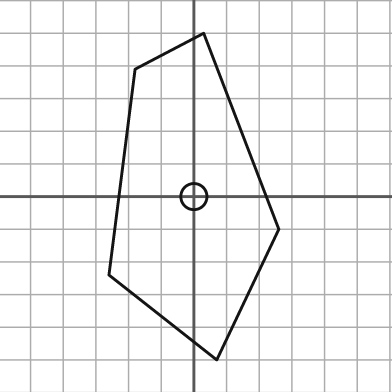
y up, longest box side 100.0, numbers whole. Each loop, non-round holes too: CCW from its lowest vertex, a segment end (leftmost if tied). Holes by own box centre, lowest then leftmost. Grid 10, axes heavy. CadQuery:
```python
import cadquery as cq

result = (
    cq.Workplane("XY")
    .moveTo(7.0, -50.0)
    .lineTo(26.0, -10.0)
    .lineTo(3.0, 50.0)
    .lineTo(-18.0, 39.0)
    .lineTo(-26.0, -24.0)
    .close()
    .moveTo(0.0, 0.0)
    .circle(4.0)
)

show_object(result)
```